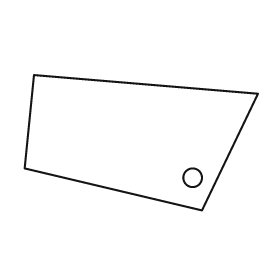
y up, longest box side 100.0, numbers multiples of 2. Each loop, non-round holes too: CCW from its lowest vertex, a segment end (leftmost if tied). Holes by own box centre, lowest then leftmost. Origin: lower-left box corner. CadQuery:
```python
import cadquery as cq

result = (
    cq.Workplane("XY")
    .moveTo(76.0, 0.0)
    .lineTo(100.0, 50.0)
    .lineTo(4.0, 58.0)
    .lineTo(0.0, 18.0)
    .close()
    .moveTo(72.0, 14.0)
    .circle(4.0)
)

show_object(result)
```